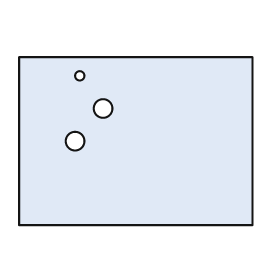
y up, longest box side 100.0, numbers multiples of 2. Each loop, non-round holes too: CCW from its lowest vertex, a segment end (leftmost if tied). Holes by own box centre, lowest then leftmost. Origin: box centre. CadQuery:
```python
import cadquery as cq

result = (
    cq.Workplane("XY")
    .moveTo(-50.0, -36.0)
    .lineTo(50.0, -36.0)
    .lineTo(50.0, 36.0)
    .lineTo(-50.0, 36.0)
    .close()
    .moveTo(-26.0, 0.0)
    .circle(4.0)
    .moveTo(-14.0, 14.0)
    .circle(4.0)
    .moveTo(-24.0, 28.0)
    .circle(2.0)
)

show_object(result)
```